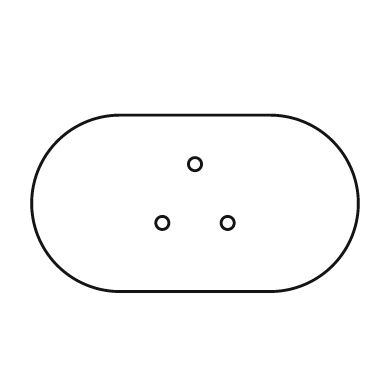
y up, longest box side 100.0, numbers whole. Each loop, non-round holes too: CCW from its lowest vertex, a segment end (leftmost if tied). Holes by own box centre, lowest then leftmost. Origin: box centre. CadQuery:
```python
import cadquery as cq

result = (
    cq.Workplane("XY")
    .moveTo(-23.0, -27.0)
    .lineTo(23.0, -27.0)
    .threePointArc((50.0, 0.0), (23.0, 27.0))
    .lineTo(-23.0, 27.0)
    .threePointArc((-50.0, 0.0), (-23.0, -27.0))
    .close()
    .moveTo(-10.0, -6.0)
    .circle(2.0)
    .moveTo(10.0, -6.0)
    .circle(2.0)
    .moveTo(0.0, 12.0)
    .circle(2.0)
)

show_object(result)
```